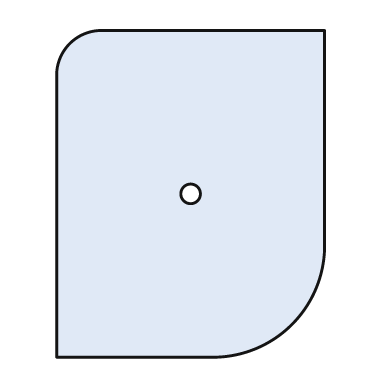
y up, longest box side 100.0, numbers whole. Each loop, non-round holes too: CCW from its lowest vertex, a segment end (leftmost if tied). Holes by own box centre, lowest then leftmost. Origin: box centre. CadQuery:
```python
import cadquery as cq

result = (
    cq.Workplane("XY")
    .moveTo(-41.0, -50.0)
    .lineTo(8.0, -50.0)
    .threePointArc((31.0, -40.0), (41.0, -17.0))
    .lineTo(41.0, 50.0)
    .lineTo(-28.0, 50.0)
    .threePointArc((-37.0, 46.0), (-41.0, 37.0))
    .close()
    .moveTo(0.0, 0.0)
    .circle(3.0)
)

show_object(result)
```